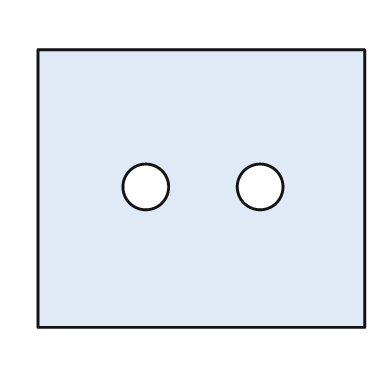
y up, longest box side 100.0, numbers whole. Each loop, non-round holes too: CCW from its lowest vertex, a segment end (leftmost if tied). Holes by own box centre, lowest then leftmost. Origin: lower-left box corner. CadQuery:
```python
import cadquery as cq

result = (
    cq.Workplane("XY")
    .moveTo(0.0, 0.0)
    .lineTo(100.0, 0.0)
    .lineTo(100.0, 85.0)
    .lineTo(0.0, 85.0)
    .close()
    .moveTo(33.0, 43.0)
    .circle(7.0)
    .moveTo(68.0, 43.0)
    .circle(7.0)
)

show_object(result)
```